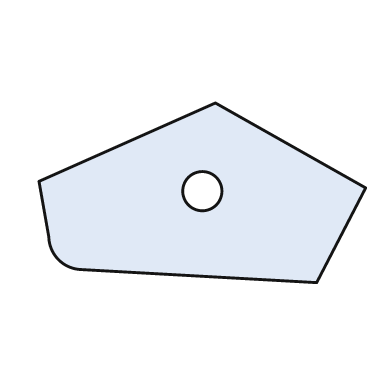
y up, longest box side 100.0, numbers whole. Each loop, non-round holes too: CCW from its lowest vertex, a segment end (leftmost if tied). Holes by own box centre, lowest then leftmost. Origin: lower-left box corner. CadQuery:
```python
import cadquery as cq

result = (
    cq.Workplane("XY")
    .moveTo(85.0, 0.0)
    .lineTo(100.0, 29.0)
    .lineTo(54.0, 55.0)
    .lineTo(0.0, 31.0)
    .lineTo(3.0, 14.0)
    .threePointArc((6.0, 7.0), (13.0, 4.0))
    .close()
    .moveTo(50.0, 28.0)
    .circle(6.0)
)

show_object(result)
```